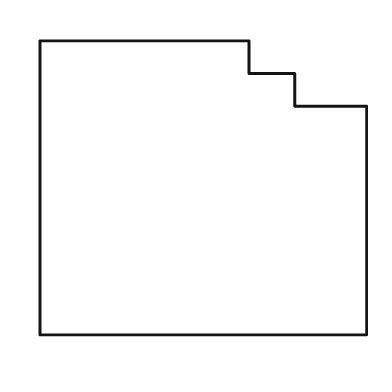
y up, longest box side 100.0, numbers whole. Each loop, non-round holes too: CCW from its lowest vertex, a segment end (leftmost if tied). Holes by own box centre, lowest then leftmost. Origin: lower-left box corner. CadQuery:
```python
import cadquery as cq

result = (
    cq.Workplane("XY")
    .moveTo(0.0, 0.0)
    .lineTo(100.0, 0.0)
    .lineTo(100.0, 70.0)
    .lineTo(78.0, 70.0)
    .lineTo(78.0, 80.0)
    .lineTo(64.0, 80.0)
    .lineTo(64.0, 90.0)
    .lineTo(0.0, 90.0)
    .close()
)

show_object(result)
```